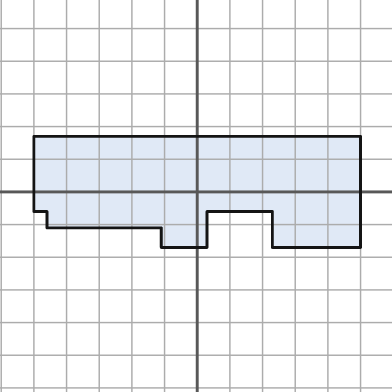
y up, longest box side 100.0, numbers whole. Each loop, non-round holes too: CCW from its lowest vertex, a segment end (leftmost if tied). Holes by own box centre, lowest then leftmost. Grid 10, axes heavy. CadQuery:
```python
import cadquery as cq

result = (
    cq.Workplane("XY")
    .moveTo(-11.0, -17.0)
    .lineTo(3.0, -17.0)
    .lineTo(3.0, -6.0)
    .lineTo(23.0, -6.0)
    .lineTo(23.0, -17.0)
    .lineTo(50.0, -17.0)
    .lineTo(50.0, 17.0)
    .lineTo(-50.0, 17.0)
    .lineTo(-50.0, -6.0)
    .lineTo(-46.0, -6.0)
    .lineTo(-46.0, -11.0)
    .lineTo(-11.0, -11.0)
    .close()
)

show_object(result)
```